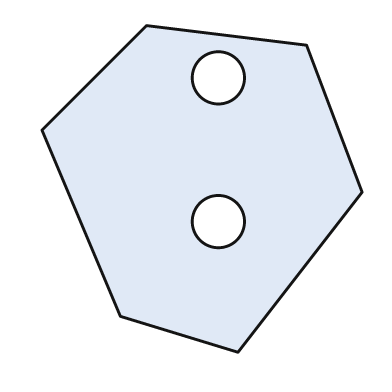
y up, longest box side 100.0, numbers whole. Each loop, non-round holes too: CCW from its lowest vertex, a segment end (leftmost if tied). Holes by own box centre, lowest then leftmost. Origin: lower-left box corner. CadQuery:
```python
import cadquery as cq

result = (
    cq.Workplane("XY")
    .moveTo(60.0, 0.0)
    .lineTo(98.0, 49.0)
    .lineTo(81.0, 94.0)
    .lineTo(32.0, 100.0)
    .lineTo(0.0, 68.0)
    .lineTo(24.0, 11.0)
    .close()
    .moveTo(54.0, 40.0)
    .circle(8.0)
    .moveTo(54.0, 84.0)
    .circle(8.0)
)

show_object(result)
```